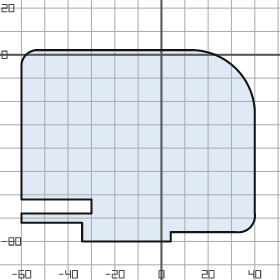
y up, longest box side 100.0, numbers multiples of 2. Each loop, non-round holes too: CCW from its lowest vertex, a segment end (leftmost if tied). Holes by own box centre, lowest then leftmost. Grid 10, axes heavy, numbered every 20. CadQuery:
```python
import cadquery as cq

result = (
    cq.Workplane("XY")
    .moveTo(-34.0, -80.0)
    .lineTo(4.0, -80.0)
    .lineTo(4.0, -76.0)
    .lineTo(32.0, -76.0)
    .threePointArc((38.0, -74.0), (40.0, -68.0))
    .lineTo(40.0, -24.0)
    .threePointArc((32.0, -6.0), (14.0, 2.0))
    .lineTo(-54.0, 2.0)
    .threePointArc((-58.0, 0.0), (-60.0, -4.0))
    .lineTo(-60.0, -62.0)
    .lineTo(-30.0, -62.0)
    .lineTo(-30.0, -68.0)
    .lineTo(-60.0, -68.0)
    .lineTo(-60.0, -72.0)
    .lineTo(-34.0, -72.0)
    .close()
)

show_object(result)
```